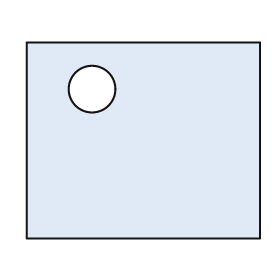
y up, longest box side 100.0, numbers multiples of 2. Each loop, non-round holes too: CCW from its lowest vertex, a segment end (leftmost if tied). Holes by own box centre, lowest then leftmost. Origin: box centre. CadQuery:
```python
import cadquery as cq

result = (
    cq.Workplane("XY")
    .moveTo(-50.0, -42.0)
    .lineTo(50.0, -42.0)
    .lineTo(50.0, 42.0)
    .lineTo(-50.0, 42.0)
    .close()
    .moveTo(-22.0, 22.0)
    .circle(10.0)
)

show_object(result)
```